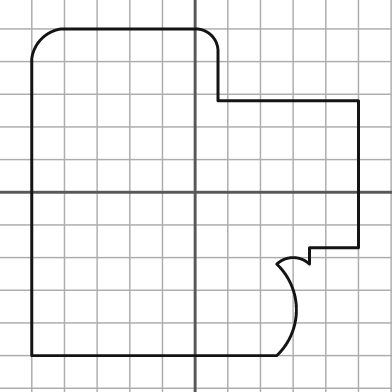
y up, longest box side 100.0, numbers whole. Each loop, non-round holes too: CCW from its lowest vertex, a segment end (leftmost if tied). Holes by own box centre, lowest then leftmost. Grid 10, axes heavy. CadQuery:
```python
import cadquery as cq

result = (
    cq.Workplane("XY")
    .moveTo(-50.0, -50.0)
    .lineTo(25.0, -50.0)
    .threePointArc((31.0, -36.0), (25.0, -22.0))
    .threePointArc((30.0, -20.0), (35.0, -22.0))
    .lineTo(35.0, -17.0)
    .lineTo(50.0, -17.0)
    .lineTo(50.0, 28.0)
    .lineTo(7.0, 28.0)
    .lineTo(7.0, 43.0)
    .threePointArc((5.0, 48.0), (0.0, 50.0))
    .lineTo(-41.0, 50.0)
    .threePointArc((-47.0, 47.0), (-50.0, 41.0))
    .close()
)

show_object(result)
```